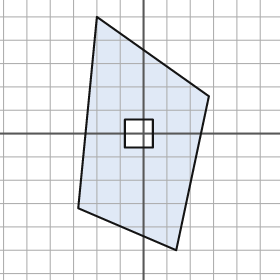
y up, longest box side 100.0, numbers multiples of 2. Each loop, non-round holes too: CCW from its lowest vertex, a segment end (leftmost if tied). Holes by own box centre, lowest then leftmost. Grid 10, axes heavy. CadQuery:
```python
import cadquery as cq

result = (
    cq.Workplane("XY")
    .moveTo(14.0, -50.0)
    .lineTo(28.0, 16.0)
    .lineTo(-20.0, 50.0)
    .lineTo(-28.0, -32.0)
    .close()
    .moveTo(-8.0, -6.0)
    .lineTo(4.0, -6.0)
    .lineTo(4.0, 6.0)
    .lineTo(-8.0, 6.0)
    .close()
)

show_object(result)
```